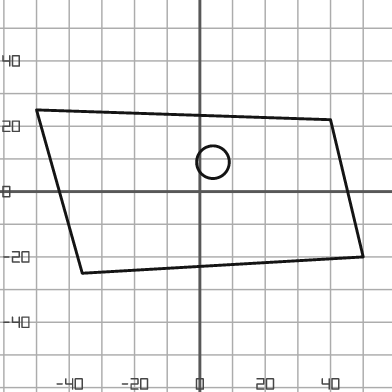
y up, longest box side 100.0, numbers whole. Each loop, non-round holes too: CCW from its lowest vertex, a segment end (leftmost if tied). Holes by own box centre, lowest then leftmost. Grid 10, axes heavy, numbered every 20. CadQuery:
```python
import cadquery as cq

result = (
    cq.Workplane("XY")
    .moveTo(-36.0, -25.0)
    .lineTo(50.0, -20.0)
    .lineTo(40.0, 22.0)
    .lineTo(-50.0, 25.0)
    .close()
    .moveTo(4.0, 9.0)
    .circle(5.0)
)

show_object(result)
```